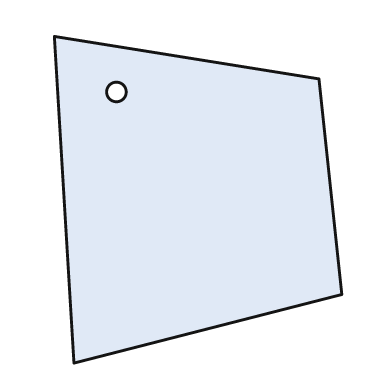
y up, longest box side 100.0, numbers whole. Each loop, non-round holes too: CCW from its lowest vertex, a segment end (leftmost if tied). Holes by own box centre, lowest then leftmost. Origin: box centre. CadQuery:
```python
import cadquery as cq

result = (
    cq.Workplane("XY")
    .moveTo(-38.0, -50.0)
    .lineTo(44.0, -29.0)
    .lineTo(37.0, 37.0)
    .lineTo(-44.0, 50.0)
    .close()
    .moveTo(-25.0, 33.0)
    .circle(3.0)
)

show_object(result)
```